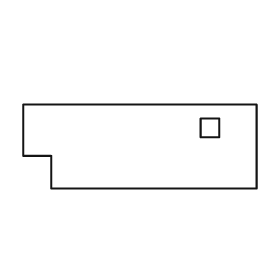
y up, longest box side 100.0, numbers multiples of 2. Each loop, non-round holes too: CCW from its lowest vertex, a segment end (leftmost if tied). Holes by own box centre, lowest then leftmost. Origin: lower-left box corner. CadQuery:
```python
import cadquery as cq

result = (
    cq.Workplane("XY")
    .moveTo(12.0, 0.0)
    .lineTo(100.0, 0.0)
    .lineTo(100.0, 36.0)
    .lineTo(0.0, 36.0)
    .lineTo(0.0, 14.0)
    .lineTo(12.0, 14.0)
    .close()
    .moveTo(76.0, 22.0)
    .lineTo(84.0, 22.0)
    .lineTo(84.0, 30.0)
    .lineTo(76.0, 30.0)
    .close()
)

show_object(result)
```